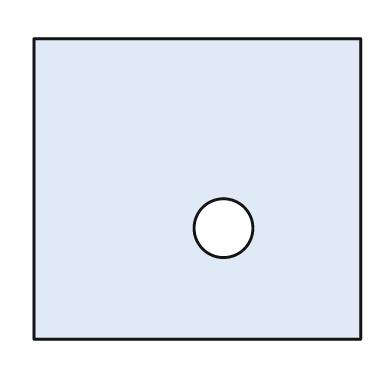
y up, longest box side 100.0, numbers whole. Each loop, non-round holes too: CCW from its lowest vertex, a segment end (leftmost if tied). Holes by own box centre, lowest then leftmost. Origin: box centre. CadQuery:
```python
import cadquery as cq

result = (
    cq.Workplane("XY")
    .moveTo(-50.0, -46.0)
    .lineTo(50.0, -46.0)
    .lineTo(50.0, 46.0)
    .lineTo(-50.0, 46.0)
    .close()
    .moveTo(8.0, -12.0)
    .circle(9.0)
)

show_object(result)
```